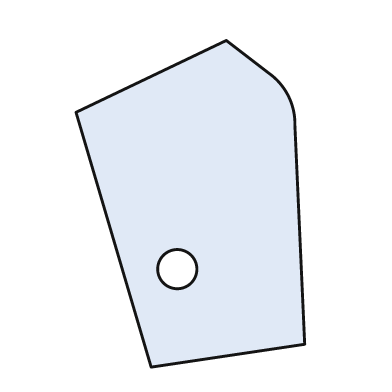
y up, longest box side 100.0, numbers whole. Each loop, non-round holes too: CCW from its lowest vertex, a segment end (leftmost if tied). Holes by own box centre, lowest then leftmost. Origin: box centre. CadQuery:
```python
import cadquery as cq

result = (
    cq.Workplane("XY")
    .moveTo(-12.0, -50.0)
    .lineTo(35.0, -43.0)
    .lineTo(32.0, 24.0)
    .threePointArc((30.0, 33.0), (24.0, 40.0))
    .lineTo(11.0, 50.0)
    .lineTo(-35.0, 28.0)
    .close()
    .moveTo(-4.0, -20.0)
    .circle(6.0)
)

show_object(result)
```